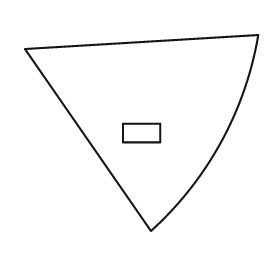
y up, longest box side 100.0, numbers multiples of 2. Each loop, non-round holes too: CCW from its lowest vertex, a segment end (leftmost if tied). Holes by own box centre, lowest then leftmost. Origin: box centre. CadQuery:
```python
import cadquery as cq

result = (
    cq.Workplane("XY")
    .moveTo(4.0, -42.0)
    .threePointArc((34.0, -4.0), (50.0, 42.0))
    .lineTo(-50.0, 36.0)
    .close()
    .moveTo(-8.0, -4.0)
    .lineTo(8.0, -4.0)
    .lineTo(8.0, 4.0)
    .lineTo(-8.0, 4.0)
    .close()
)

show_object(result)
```